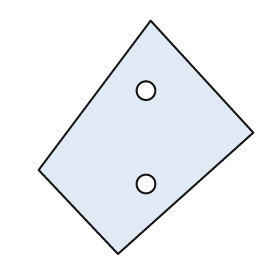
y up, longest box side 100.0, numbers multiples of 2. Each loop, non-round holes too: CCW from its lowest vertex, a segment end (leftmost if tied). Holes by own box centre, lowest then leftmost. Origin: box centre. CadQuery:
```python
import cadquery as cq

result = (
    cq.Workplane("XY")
    .moveTo(-12.0, -50.0)
    .lineTo(46.0, 2.0)
    .lineTo(2.0, 50.0)
    .lineTo(-46.0, -14.0)
    .close()
    .moveTo(0.0, -20.0)
    .circle(4.0)
    .moveTo(0.0, 20.0)
    .circle(4.0)
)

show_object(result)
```